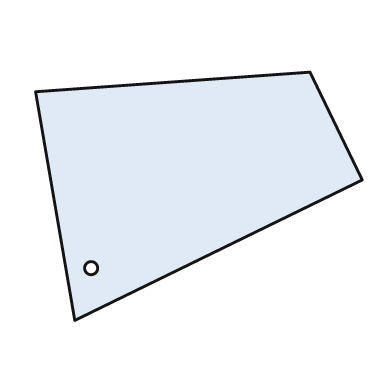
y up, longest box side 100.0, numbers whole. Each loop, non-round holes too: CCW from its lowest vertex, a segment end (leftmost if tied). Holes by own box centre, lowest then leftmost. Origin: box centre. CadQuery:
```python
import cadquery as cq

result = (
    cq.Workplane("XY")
    .moveTo(-38.0, -38.0)
    .lineTo(50.0, 5.0)
    .lineTo(34.0, 38.0)
    .lineTo(-50.0, 32.0)
    .close()
    .moveTo(-33.0, -22.0)
    .circle(2.0)
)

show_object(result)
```